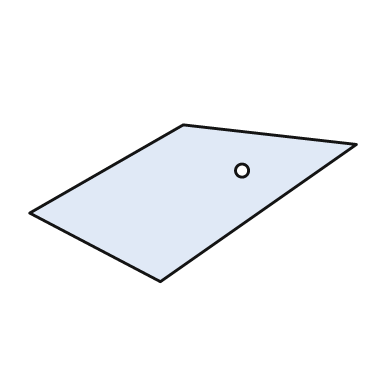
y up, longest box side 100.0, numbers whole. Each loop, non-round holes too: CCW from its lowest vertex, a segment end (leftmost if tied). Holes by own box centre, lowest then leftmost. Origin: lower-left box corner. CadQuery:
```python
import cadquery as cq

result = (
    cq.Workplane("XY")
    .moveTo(40.0, 0.0)
    .lineTo(100.0, 42.0)
    .lineTo(47.0, 48.0)
    .lineTo(0.0, 21.0)
    .close()
    .moveTo(65.0, 34.0)
    .circle(2.0)
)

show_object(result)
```